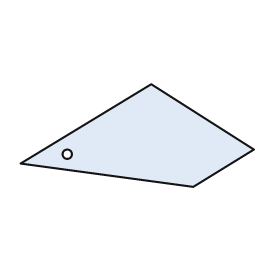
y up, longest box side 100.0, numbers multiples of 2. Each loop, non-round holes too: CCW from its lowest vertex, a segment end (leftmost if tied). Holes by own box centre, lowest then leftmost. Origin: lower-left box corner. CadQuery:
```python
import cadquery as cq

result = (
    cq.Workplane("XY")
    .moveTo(74.0, 0.0)
    .lineTo(100.0, 16.0)
    .lineTo(56.0, 44.0)
    .lineTo(0.0, 10.0)
    .close()
    .moveTo(20.0, 14.0)
    .circle(2.0)
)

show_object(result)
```